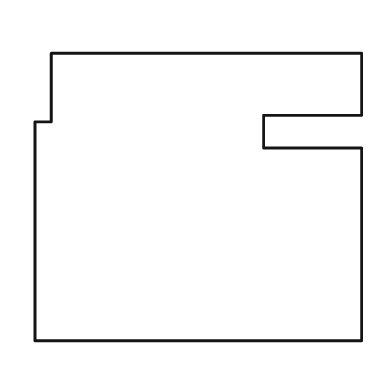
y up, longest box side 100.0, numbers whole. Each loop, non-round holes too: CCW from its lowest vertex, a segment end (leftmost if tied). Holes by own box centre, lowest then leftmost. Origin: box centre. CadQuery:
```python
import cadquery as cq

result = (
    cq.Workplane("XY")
    .moveTo(-50.0, -44.0)
    .lineTo(50.0, -44.0)
    .lineTo(50.0, 15.0)
    .lineTo(20.0, 15.0)
    .lineTo(20.0, 25.0)
    .lineTo(50.0, 25.0)
    .lineTo(50.0, 44.0)
    .lineTo(-45.0, 44.0)
    .lineTo(-45.0, 23.0)
    .lineTo(-50.0, 23.0)
    .close()
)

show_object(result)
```